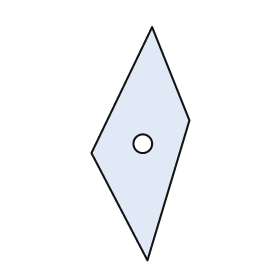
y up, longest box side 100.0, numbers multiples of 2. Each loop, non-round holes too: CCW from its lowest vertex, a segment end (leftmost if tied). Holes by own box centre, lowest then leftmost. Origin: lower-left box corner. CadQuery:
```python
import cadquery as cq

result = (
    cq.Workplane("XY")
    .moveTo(24.0, 0.0)
    .lineTo(42.0, 60.0)
    .lineTo(26.0, 100.0)
    .lineTo(0.0, 46.0)
    .close()
    .moveTo(22.0, 50.0)
    .circle(4.0)
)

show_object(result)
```